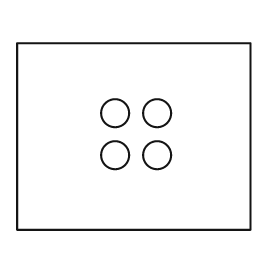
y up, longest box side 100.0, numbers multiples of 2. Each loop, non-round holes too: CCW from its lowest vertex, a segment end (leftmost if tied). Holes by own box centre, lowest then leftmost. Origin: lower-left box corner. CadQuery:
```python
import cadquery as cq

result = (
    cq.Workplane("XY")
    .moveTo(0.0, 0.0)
    .lineTo(100.0, 0.0)
    .lineTo(100.0, 80.0)
    .lineTo(0.0, 80.0)
    .close()
    .moveTo(42.0, 32.0)
    .circle(6.0)
    .moveTo(60.0, 32.0)
    .circle(6.0)
    .moveTo(42.0, 50.0)
    .circle(6.0)
    .moveTo(60.0, 50.0)
    .circle(6.0)
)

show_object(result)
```